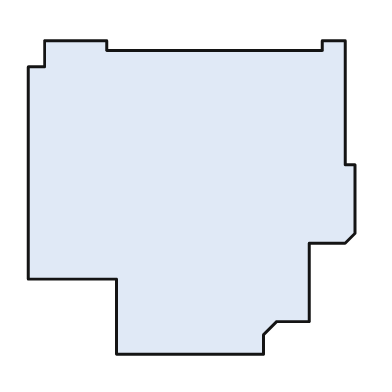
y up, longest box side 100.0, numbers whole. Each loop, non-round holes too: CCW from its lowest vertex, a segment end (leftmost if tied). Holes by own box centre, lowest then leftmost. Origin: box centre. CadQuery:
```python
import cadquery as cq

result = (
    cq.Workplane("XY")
    .moveTo(-23.0, -48.0)
    .lineTo(22.0, -48.0)
    .lineTo(22.0, -42.0)
    .lineTo(26.0, -38.0)
    .lineTo(36.0, -38.0)
    .lineTo(36.0, -14.0)
    .lineTo(47.0, -14.0)
    .lineTo(50.0, -11.0)
    .lineTo(50.0, 10.0)
    .lineTo(47.0, 10.0)
    .lineTo(47.0, 48.0)
    .lineTo(40.0, 48.0)
    .lineTo(40.0, 45.0)
    .lineTo(-26.0, 45.0)
    .lineTo(-26.0, 48.0)
    .lineTo(-45.0, 48.0)
    .lineTo(-45.0, 40.0)
    .lineTo(-50.0, 40.0)
    .lineTo(-50.0, -25.0)
    .lineTo(-23.0, -25.0)
    .close()
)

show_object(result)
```